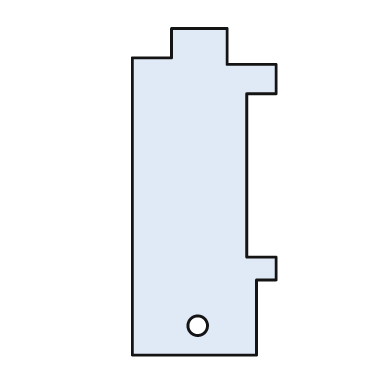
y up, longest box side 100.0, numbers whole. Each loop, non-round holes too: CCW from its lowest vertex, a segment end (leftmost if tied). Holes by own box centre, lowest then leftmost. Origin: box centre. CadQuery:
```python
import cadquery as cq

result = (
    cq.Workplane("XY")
    .moveTo(-22.0, -50.0)
    .lineTo(16.0, -50.0)
    .lineTo(16.0, -27.0)
    .lineTo(22.0, -27.0)
    .lineTo(22.0, -20.0)
    .lineTo(13.0, -20.0)
    .lineTo(13.0, 30.0)
    .lineTo(22.0, 30.0)
    .lineTo(22.0, 39.0)
    .lineTo(7.0, 39.0)
    .lineTo(7.0, 50.0)
    .lineTo(-10.0, 50.0)
    .lineTo(-10.0, 41.0)
    .lineTo(-22.0, 41.0)
    .close()
    .moveTo(-2.0, -41.0)
    .circle(3.0)
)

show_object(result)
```